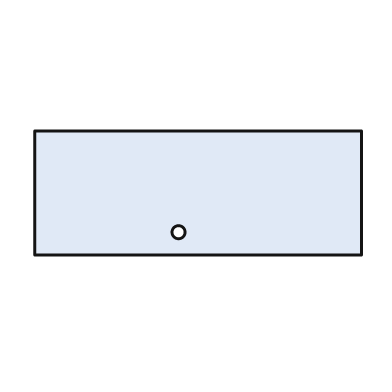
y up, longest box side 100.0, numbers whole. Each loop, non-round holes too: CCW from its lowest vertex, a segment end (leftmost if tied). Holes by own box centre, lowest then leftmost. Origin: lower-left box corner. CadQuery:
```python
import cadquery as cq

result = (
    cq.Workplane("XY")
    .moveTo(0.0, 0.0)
    .lineTo(100.0, 0.0)
    .lineTo(100.0, 38.0)
    .lineTo(0.0, 38.0)
    .close()
    .moveTo(44.0, 7.0)
    .circle(2.0)
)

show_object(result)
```